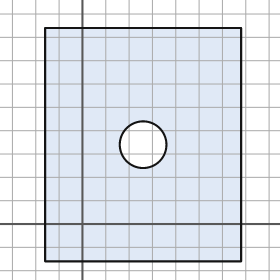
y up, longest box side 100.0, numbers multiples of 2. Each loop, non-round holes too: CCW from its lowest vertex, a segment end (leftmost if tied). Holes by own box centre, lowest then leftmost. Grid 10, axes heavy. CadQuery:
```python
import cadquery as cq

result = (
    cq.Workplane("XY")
    .moveTo(-16.0, -16.0)
    .lineTo(68.0, -16.0)
    .lineTo(68.0, 84.0)
    .lineTo(-16.0, 84.0)
    .close()
    .moveTo(26.0, 34.0)
    .circle(10.0)
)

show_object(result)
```